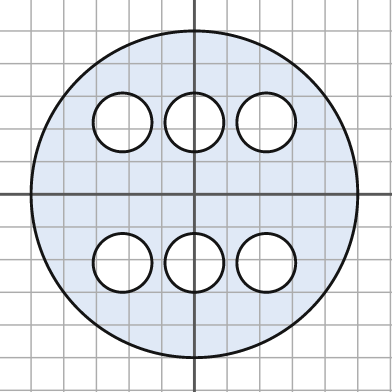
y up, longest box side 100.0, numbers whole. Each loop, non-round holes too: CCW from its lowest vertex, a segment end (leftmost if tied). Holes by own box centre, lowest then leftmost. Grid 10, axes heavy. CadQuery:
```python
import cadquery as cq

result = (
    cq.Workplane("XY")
    .moveTo(0.0, 0.0)
    .circle(50.0)
    .moveTo(-22.0, -21.0)
    .circle(9.0)
    .moveTo(0.0, -21.0)
    .circle(9.0)
    .moveTo(22.0, -21.0)
    .circle(9.0)
    .moveTo(-22.0, 22.0)
    .circle(9.0)
    .moveTo(0.0, 22.0)
    .circle(9.0)
    .moveTo(22.0, 22.0)
    .circle(9.0)
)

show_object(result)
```